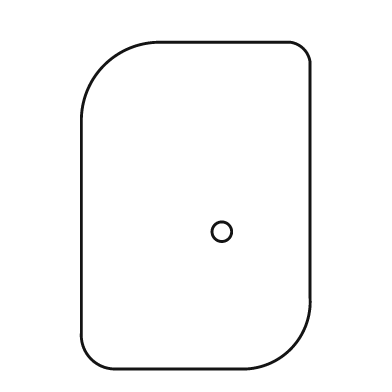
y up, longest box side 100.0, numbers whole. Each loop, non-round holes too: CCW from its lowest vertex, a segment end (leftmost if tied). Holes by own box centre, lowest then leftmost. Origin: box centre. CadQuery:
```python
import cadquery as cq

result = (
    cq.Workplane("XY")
    .moveTo(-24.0, -50.0)
    .lineTo(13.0, -50.0)
    .threePointArc((29.0, -44.0), (35.0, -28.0))
    .lineTo(35.0, 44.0)
    .threePointArc((33.0, 48.0), (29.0, 50.0))
    .lineTo(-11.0, 50.0)
    .threePointArc((-28.0, 43.0), (-35.0, 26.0))
    .lineTo(-35.0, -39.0)
    .threePointArc((-32.0, -47.0), (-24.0, -50.0))
    .close()
    .moveTo(8.0, -8.0)
    .circle(3.0)
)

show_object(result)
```